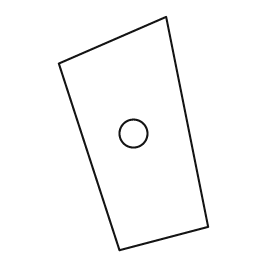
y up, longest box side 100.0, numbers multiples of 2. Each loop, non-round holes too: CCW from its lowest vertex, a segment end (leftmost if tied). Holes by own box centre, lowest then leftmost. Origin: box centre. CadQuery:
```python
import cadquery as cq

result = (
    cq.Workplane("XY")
    .moveTo(-6.0, -50.0)
    .lineTo(32.0, -40.0)
    .lineTo(14.0, 50.0)
    .lineTo(-32.0, 30.0)
    .close()
    .moveTo(0.0, 0.0)
    .circle(6.0)
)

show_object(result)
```